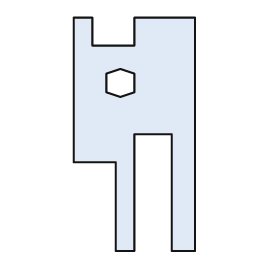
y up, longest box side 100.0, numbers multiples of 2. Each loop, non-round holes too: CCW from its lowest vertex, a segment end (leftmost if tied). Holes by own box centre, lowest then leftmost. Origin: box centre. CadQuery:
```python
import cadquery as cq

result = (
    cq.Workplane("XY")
    .moveTo(-8.0, -50.0)
    .lineTo(0.0, -50.0)
    .lineTo(0.0, 0.0)
    .lineTo(16.0, 0.0)
    .lineTo(16.0, -50.0)
    .lineTo(26.0, -50.0)
    .lineTo(26.0, 50.0)
    .lineTo(0.0, 50.0)
    .lineTo(0.0, 38.0)
    .lineTo(-18.0, 38.0)
    .lineTo(-18.0, 50.0)
    .lineTo(-26.0, 50.0)
    .lineTo(-26.0, -12.0)
    .lineTo(-8.0, -12.0)
    .close()
    .moveTo(-6.0, 16.0)
    .lineTo(0.0, 18.0)
    .lineTo(0.0, 26.0)
    .lineTo(-6.0, 28.0)
    .lineTo(-12.0, 26.0)
    .lineTo(-12.0, 18.0)
    .close()
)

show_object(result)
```